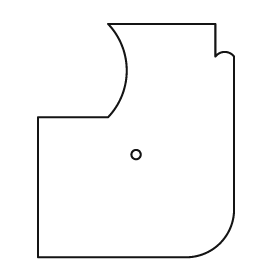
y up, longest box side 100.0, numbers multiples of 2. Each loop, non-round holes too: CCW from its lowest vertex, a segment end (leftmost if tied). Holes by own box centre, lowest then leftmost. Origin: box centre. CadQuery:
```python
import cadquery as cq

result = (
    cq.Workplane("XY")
    .moveTo(-42.0, -50.0)
    .lineTo(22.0, -50.0)
    .threePointArc((36.0, -44.0), (42.0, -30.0))
    .lineTo(42.0, 36.0)
    .threePointArc((38.0, 38.0), (34.0, 36.0))
    .lineTo(34.0, 50.0)
    .lineTo(-12.0, 50.0)
    .threePointArc((-4.0, 30.0), (-12.0, 10.0))
    .lineTo(-42.0, 10.0)
    .close()
    .moveTo(0.0, -6.0)
    .circle(2.0)
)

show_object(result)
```